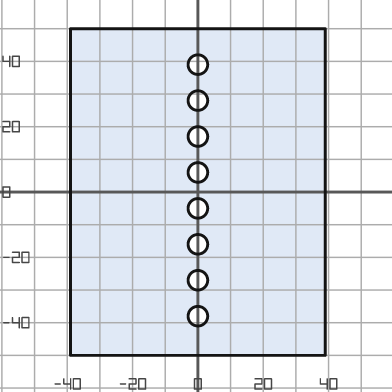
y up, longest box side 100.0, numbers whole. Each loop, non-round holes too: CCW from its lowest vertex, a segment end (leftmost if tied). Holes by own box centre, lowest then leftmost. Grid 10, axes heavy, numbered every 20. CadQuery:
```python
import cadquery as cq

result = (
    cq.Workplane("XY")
    .moveTo(-39.0, -50.0)
    .lineTo(39.0, -50.0)
    .lineTo(39.0, 50.0)
    .lineTo(-39.0, 50.0)
    .close()
    .moveTo(0.0, -38.0)
    .circle(3.0)
    .moveTo(0.0, -27.0)
    .circle(3.0)
    .moveTo(0.0, -16.0)
    .circle(3.0)
    .moveTo(0.0, -5.0)
    .circle(3.0)
    .moveTo(0.0, 6.0)
    .circle(3.0)
    .moveTo(0.0, 17.0)
    .circle(3.0)
    .moveTo(0.0, 28.0)
    .circle(3.0)
    .moveTo(0.0, 39.0)
    .circle(3.0)
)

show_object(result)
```